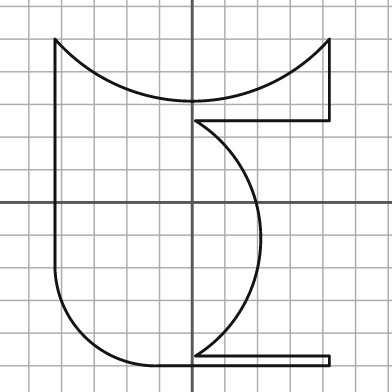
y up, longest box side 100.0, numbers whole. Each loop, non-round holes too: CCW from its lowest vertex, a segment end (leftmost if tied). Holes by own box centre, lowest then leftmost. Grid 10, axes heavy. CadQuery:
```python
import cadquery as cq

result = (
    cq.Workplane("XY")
    .moveTo(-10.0, -50.0)
    .lineTo(42.0, -50.0)
    .lineTo(42.0, -47.0)
    .lineTo(1.0, -47.0)
    .threePointArc((21.0, -11.0), (1.0, 25.0))
    .lineTo(42.0, 25.0)
    .lineTo(42.0, 50.0)
    .threePointArc((0.0, 31.0), (-42.0, 50.0))
    .lineTo(-42.0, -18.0)
    .threePointArc((-33.0, -41.0), (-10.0, -50.0))
    .close()
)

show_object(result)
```